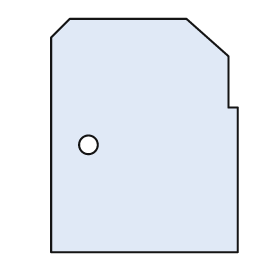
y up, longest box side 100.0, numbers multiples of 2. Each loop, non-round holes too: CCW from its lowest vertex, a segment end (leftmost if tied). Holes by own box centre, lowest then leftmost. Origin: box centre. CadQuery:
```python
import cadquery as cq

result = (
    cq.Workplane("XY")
    .moveTo(-40.0, -50.0)
    .lineTo(40.0, -50.0)
    .lineTo(40.0, 12.0)
    .lineTo(36.0, 12.0)
    .lineTo(36.0, 34.0)
    .lineTo(18.0, 50.0)
    .lineTo(-32.0, 50.0)
    .lineTo(-40.0, 42.0)
    .close()
    .moveTo(-24.0, -4.0)
    .circle(4.0)
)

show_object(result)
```